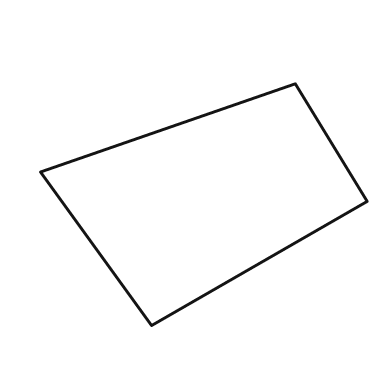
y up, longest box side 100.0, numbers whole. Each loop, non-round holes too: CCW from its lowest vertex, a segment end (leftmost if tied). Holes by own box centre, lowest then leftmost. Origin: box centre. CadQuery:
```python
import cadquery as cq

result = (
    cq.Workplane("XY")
    .moveTo(-16.0, -37.0)
    .lineTo(50.0, 1.0)
    .lineTo(28.0, 37.0)
    .lineTo(-50.0, 10.0)
    .close()
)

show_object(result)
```